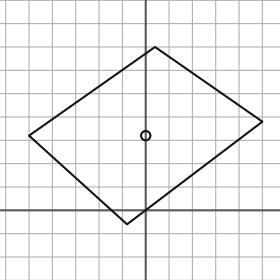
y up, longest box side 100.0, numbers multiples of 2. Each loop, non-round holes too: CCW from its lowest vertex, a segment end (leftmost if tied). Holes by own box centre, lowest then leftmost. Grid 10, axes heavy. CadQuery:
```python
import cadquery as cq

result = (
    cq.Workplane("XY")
    .moveTo(-8.0, -6.0)
    .lineTo(50.0, 38.0)
    .lineTo(4.0, 70.0)
    .lineTo(-50.0, 32.0)
    .close()
    .moveTo(0.0, 32.0)
    .circle(2.0)
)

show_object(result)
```